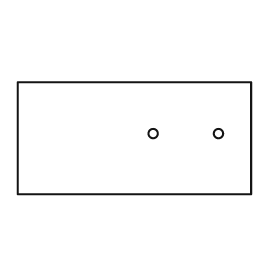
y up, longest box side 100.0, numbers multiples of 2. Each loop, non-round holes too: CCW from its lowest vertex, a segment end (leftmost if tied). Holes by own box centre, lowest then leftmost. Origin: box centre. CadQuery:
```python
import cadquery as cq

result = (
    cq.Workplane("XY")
    .moveTo(-50.0, -24.0)
    .lineTo(50.0, -24.0)
    .lineTo(50.0, 24.0)
    .lineTo(-50.0, 24.0)
    .close()
    .moveTo(8.0, 2.0)
    .circle(2.0)
    .moveTo(36.0, 2.0)
    .circle(2.0)
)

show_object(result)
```